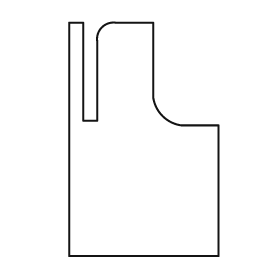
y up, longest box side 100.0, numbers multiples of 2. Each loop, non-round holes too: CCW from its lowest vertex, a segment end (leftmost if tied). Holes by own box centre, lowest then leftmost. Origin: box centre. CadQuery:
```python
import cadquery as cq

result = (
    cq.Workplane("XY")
    .moveTo(-32.0, -50.0)
    .lineTo(32.0, -50.0)
    .lineTo(32.0, 6.0)
    .lineTo(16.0, 6.0)
    .threePointArc((8.0, 10.0), (4.0, 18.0))
    .lineTo(4.0, 50.0)
    .lineTo(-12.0, 50.0)
    .threePointArc((-18.0, 48.0), (-20.0, 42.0))
    .lineTo(-20.0, 8.0)
    .lineTo(-26.0, 8.0)
    .lineTo(-26.0, 50.0)
    .lineTo(-32.0, 50.0)
    .close()
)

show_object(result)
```